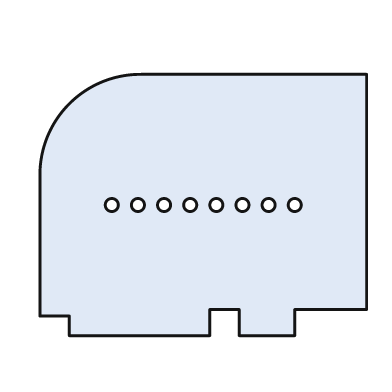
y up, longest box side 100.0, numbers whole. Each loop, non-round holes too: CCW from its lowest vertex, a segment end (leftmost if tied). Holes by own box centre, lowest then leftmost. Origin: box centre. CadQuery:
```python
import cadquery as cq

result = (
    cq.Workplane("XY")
    .moveTo(-41.0, -40.0)
    .lineTo(2.0, -40.0)
    .lineTo(2.0, -32.0)
    .lineTo(11.0, -32.0)
    .lineTo(11.0, -40.0)
    .lineTo(28.0, -40.0)
    .lineTo(28.0, -32.0)
    .lineTo(50.0, -32.0)
    .lineTo(50.0, 40.0)
    .lineTo(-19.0, 40.0)
    .threePointArc((-41.0, 31.0), (-50.0, 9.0))
    .lineTo(-50.0, -34.0)
    .lineTo(-41.0, -34.0)
    .close()
    .moveTo(-28.0, 0.0)
    .circle(2.0)
    .moveTo(-20.0, 0.0)
    .circle(2.0)
    .moveTo(-12.0, 0.0)
    .circle(2.0)
    .moveTo(-4.0, 0.0)
    .circle(2.0)
    .moveTo(4.0, 0.0)
    .circle(2.0)
    .moveTo(12.0, 0.0)
    .circle(2.0)
    .moveTo(20.0, 0.0)
    .circle(2.0)
    .moveTo(28.0, 0.0)
    .circle(2.0)
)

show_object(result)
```